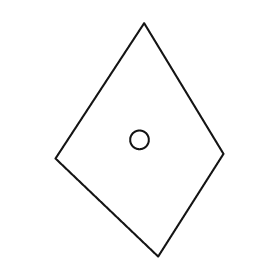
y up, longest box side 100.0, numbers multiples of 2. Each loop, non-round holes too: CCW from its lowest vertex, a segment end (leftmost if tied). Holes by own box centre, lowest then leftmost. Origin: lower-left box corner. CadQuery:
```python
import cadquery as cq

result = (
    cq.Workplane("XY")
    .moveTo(44.0, 0.0)
    .lineTo(72.0, 44.0)
    .lineTo(38.0, 100.0)
    .lineTo(0.0, 42.0)
    .close()
    .moveTo(36.0, 50.0)
    .circle(4.0)
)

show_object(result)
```